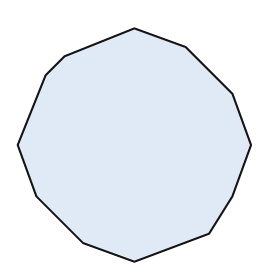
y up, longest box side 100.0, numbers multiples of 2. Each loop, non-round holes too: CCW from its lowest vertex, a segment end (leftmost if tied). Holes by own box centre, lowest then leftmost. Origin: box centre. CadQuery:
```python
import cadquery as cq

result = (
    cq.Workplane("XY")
    .moveTo(0.0, -50.0)
    .lineTo(32.0, -38.0)
    .lineTo(42.0, -22.0)
    .lineTo(50.0, 0.0)
    .lineTo(42.0, 22.0)
    .lineTo(22.0, 42.0)
    .lineTo(0.0, 50.0)
    .lineTo(-30.0, 38.0)
    .lineTo(-38.0, 30.0)
    .lineTo(-50.0, 0.0)
    .lineTo(-42.0, -22.0)
    .lineTo(-22.0, -42.0)
    .close()
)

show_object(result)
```